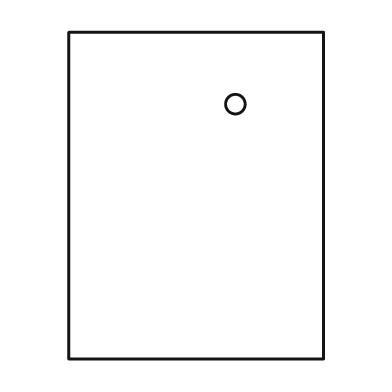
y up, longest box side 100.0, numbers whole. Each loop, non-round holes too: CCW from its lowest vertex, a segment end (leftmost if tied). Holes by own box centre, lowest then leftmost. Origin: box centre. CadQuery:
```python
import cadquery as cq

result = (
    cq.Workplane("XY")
    .moveTo(-39.0, -50.0)
    .lineTo(39.0, -50.0)
    .lineTo(39.0, 50.0)
    .lineTo(-39.0, 50.0)
    .close()
    .moveTo(12.0, 28.0)
    .circle(3.0)
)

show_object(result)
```